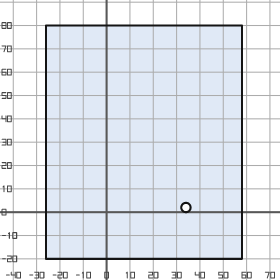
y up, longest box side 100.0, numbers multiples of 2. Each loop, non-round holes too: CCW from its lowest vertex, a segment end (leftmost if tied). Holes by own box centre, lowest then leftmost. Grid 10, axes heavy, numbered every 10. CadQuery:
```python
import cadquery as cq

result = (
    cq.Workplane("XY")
    .moveTo(-26.0, -20.0)
    .lineTo(58.0, -20.0)
    .lineTo(58.0, 80.0)
    .lineTo(-26.0, 80.0)
    .close()
    .moveTo(34.0, 2.0)
    .circle(2.0)
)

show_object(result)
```